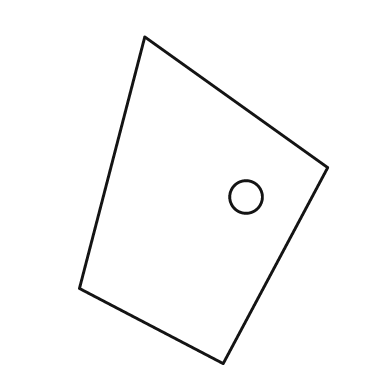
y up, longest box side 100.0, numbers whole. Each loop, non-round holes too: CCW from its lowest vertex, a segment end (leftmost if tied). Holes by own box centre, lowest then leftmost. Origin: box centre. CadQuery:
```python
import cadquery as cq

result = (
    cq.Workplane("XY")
    .moveTo(6.0, -50.0)
    .lineTo(38.0, 10.0)
    .lineTo(-18.0, 50.0)
    .lineTo(-38.0, -27.0)
    .close()
    .moveTo(13.0, 1.0)
    .circle(5.0)
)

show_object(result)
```